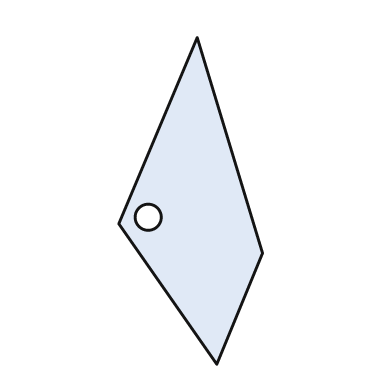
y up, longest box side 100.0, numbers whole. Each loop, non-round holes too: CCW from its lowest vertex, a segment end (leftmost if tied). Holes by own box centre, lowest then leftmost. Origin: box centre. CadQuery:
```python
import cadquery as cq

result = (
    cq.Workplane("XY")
    .moveTo(8.0, -50.0)
    .lineTo(22.0, -16.0)
    .lineTo(2.0, 50.0)
    .lineTo(-22.0, -7.0)
    .close()
    .moveTo(-13.0, -5.0)
    .circle(4.0)
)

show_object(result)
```